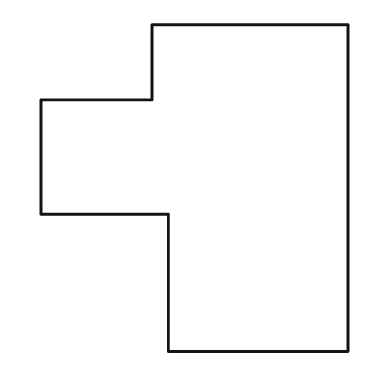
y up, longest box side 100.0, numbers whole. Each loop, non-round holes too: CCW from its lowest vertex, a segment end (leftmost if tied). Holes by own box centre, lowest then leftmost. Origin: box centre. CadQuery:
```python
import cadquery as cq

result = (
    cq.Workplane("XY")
    .moveTo(-8.0, -50.0)
    .lineTo(47.0, -50.0)
    .lineTo(47.0, 50.0)
    .lineTo(-13.0, 50.0)
    .lineTo(-13.0, 27.0)
    .lineTo(-47.0, 27.0)
    .lineTo(-47.0, -8.0)
    .lineTo(-8.0, -8.0)
    .close()
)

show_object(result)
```